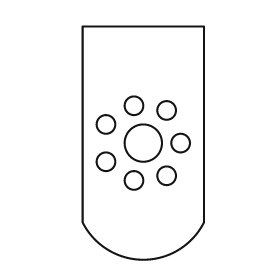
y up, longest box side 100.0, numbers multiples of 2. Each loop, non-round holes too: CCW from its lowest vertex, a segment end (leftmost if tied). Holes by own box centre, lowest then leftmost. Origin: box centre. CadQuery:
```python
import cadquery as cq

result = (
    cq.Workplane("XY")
    .moveTo(-26.0, -34.0)
    .threePointArc((0.0, -50.0), (26.0, -34.0))
    .lineTo(26.0, 50.0)
    .lineTo(-26.0, 50.0)
    .close()
    .moveTo(-4.0, -16.0)
    .circle(4.0)
    .moveTo(10.0, -14.0)
    .circle(4.0)
    .moveTo(-16.0, -8.0)
    .circle(4.0)
    .moveTo(0.0, 0.0)
    .circle(8.0)
    .moveTo(16.0, 0.0)
    .circle(4.0)
    .moveTo(-16.0, 8.0)
    .circle(4.0)
    .moveTo(10.0, 14.0)
    .circle(4.0)
    .moveTo(-4.0, 16.0)
    .circle(4.0)
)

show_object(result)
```